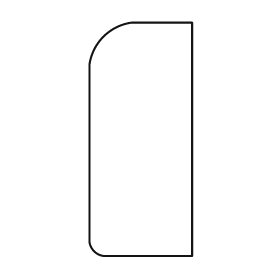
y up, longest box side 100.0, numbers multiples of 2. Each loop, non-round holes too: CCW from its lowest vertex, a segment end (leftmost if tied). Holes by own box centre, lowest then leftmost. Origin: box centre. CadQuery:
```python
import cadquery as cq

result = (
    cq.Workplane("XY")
    .moveTo(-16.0, -50.0)
    .lineTo(22.0, -50.0)
    .lineTo(22.0, 50.0)
    .lineTo(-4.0, 50.0)
    .threePointArc((-16.0, 44.0), (-22.0, 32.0))
    .lineTo(-22.0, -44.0)
    .threePointArc((-20.0, -48.0), (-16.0, -50.0))
    .close()
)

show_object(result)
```